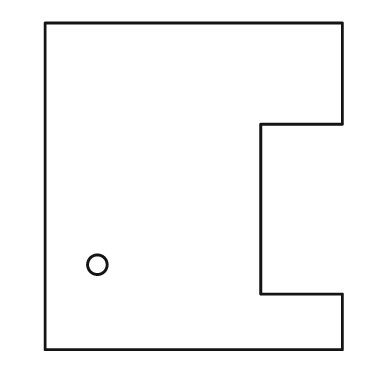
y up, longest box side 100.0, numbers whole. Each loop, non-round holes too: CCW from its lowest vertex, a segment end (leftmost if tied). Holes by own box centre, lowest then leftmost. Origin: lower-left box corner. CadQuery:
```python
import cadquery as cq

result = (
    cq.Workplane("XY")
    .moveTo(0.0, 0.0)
    .lineTo(91.0, 0.0)
    .lineTo(91.0, 17.0)
    .lineTo(66.0, 17.0)
    .lineTo(66.0, 69.0)
    .lineTo(91.0, 69.0)
    .lineTo(91.0, 100.0)
    .lineTo(0.0, 100.0)
    .close()
    .moveTo(16.0, 26.0)
    .circle(3.0)
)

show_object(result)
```